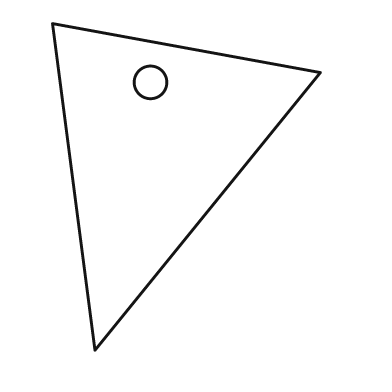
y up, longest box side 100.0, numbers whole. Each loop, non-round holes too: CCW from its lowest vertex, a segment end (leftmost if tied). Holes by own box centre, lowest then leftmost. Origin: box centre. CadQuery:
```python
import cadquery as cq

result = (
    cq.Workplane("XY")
    .moveTo(-28.0, -50.0)
    .lineTo(41.0, 35.0)
    .lineTo(-41.0, 50.0)
    .close()
    .moveTo(-11.0, 32.0)
    .circle(5.0)
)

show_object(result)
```